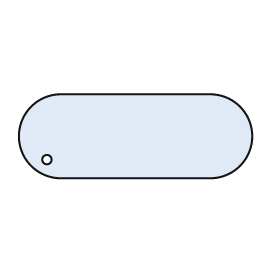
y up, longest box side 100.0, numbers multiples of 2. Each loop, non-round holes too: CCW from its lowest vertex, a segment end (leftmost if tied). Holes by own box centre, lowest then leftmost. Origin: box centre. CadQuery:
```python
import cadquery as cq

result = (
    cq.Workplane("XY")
    .moveTo(-32.0, -18.0)
    .lineTo(32.0, -18.0)
    .threePointArc((50.0, 0.0), (32.0, 18.0))
    .lineTo(-32.0, 18.0)
    .threePointArc((-50.0, 0.0), (-32.0, -18.0))
    .close()
    .moveTo(-38.0, -10.0)
    .circle(2.0)
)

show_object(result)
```